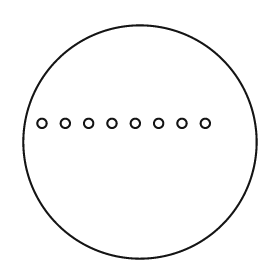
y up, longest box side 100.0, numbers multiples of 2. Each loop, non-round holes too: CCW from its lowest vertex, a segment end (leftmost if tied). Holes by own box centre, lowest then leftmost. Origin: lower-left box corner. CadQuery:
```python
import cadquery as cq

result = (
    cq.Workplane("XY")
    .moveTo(50.0, 50.0)
    .circle(50.0)
    .moveTo(8.0, 58.0)
    .circle(2.0)
    .moveTo(18.0, 58.0)
    .circle(2.0)
    .moveTo(28.0, 58.0)
    .circle(2.0)
    .moveTo(38.0, 58.0)
    .circle(2.0)
    .moveTo(48.0, 58.0)
    .circle(2.0)
    .moveTo(58.0, 58.0)
    .circle(2.0)
    .moveTo(68.0, 58.0)
    .circle(2.0)
    .moveTo(78.0, 58.0)
    .circle(2.0)
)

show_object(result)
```